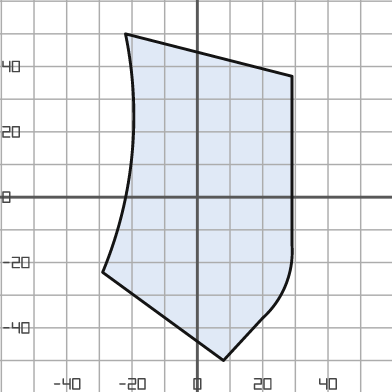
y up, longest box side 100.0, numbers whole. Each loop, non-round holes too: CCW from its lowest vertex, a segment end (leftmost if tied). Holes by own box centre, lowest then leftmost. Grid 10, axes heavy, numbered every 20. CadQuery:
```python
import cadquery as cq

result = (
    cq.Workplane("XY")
    .moveTo(8.0, -50.0)
    .lineTo(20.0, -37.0)
    .threePointArc((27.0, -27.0), (29.0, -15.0))
    .lineTo(29.0, 37.0)
    .lineTo(-22.0, 50.0)
    .threePointArc((-20.0, 13.0), (-29.0, -23.0))
    .close()
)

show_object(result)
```